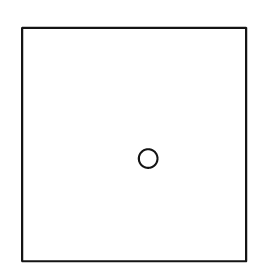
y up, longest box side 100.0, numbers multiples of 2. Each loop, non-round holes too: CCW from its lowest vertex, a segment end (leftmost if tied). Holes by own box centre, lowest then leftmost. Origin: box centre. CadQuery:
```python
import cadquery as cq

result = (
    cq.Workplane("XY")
    .moveTo(-48.0, -50.0)
    .lineTo(48.0, -50.0)
    .lineTo(48.0, 50.0)
    .lineTo(-48.0, 50.0)
    .close()
    .moveTo(6.0, -6.0)
    .circle(4.0)
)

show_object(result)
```